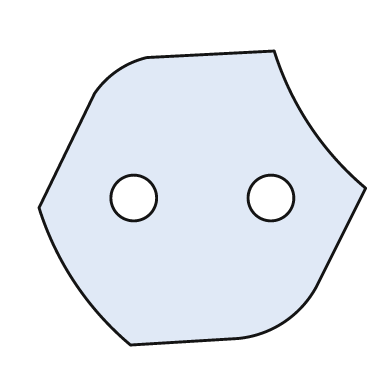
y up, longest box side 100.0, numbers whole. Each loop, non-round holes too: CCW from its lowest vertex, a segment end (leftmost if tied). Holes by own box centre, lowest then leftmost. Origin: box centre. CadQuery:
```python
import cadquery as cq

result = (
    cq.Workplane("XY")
    .moveTo(-22.0, -45.0)
    .lineTo(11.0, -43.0)
    .threePointArc((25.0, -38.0), (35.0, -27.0))
    .lineTo(50.0, 3.0)
    .threePointArc((33.0, 22.0), (22.0, 45.0))
    .lineTo(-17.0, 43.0)
    .threePointArc((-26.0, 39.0), (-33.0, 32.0))
    .lineTo(-50.0, -3.0)
    .threePointArc((-39.0, -26.0), (-22.0, -45.0))
    .close()
    .moveTo(-21.0, 0.0)
    .circle(7.0)
    .moveTo(21.0, 0.0)
    .circle(7.0)
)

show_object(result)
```